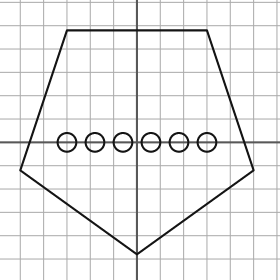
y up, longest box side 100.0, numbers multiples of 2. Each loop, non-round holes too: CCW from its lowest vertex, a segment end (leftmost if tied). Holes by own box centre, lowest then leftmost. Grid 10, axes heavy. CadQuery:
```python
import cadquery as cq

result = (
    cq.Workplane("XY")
    .moveTo(0.0, -48.0)
    .lineTo(50.0, -12.0)
    .lineTo(30.0, 48.0)
    .lineTo(-30.0, 48.0)
    .lineTo(-50.0, -12.0)
    .close()
    .moveTo(-30.0, 0.0)
    .circle(4.0)
    .moveTo(-18.0, 0.0)
    .circle(4.0)
    .moveTo(-6.0, 0.0)
    .circle(4.0)
    .moveTo(6.0, 0.0)
    .circle(4.0)
    .moveTo(18.0, 0.0)
    .circle(4.0)
    .moveTo(30.0, 0.0)
    .circle(4.0)
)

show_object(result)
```